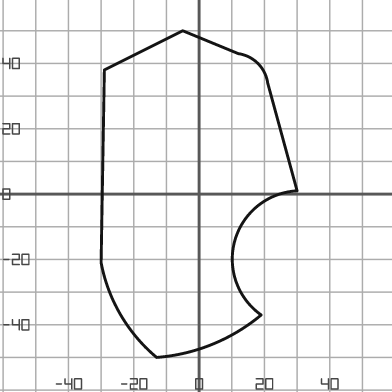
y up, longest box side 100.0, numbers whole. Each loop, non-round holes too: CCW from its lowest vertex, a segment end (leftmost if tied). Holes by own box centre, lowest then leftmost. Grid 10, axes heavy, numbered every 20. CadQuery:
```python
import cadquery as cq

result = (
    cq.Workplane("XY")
    .moveTo(-13.0, -50.0)
    .threePointArc((4.0, -46.0), (19.0, -37.0))
    .threePointArc((11.0, -14.0), (30.0, 1.0))
    .lineTo(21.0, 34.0)
    .threePointArc((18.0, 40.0), (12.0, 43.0))
    .lineTo(-5.0, 50.0)
    .lineTo(-29.0, 38.0)
    .lineTo(-30.0, -21.0)
    .threePointArc((-24.0, -37.0), (-13.0, -50.0))
    .close()
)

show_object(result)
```